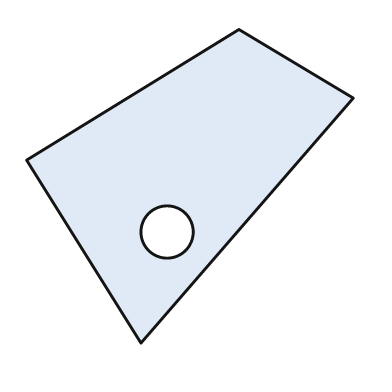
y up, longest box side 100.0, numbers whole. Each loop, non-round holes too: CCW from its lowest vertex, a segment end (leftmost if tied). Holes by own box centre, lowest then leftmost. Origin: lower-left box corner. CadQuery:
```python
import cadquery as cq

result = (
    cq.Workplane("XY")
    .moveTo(35.0, 0.0)
    .lineTo(100.0, 75.0)
    .lineTo(65.0, 96.0)
    .lineTo(0.0, 56.0)
    .close()
    .moveTo(43.0, 34.0)
    .circle(8.0)
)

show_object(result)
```